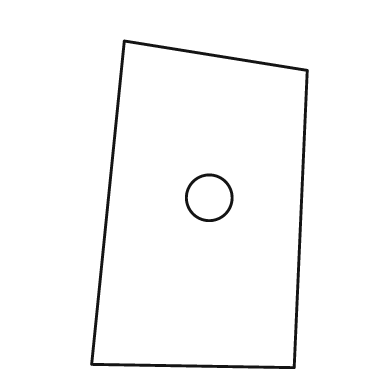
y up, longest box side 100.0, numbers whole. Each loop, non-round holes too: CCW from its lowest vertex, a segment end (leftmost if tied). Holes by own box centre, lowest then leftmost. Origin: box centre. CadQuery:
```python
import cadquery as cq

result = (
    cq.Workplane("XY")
    .moveTo(29.0, -50.0)
    .lineTo(33.0, 41.0)
    .lineTo(-23.0, 50.0)
    .lineTo(-33.0, -49.0)
    .close()
    .moveTo(3.0, 2.0)
    .circle(7.0)
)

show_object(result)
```